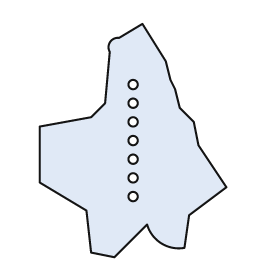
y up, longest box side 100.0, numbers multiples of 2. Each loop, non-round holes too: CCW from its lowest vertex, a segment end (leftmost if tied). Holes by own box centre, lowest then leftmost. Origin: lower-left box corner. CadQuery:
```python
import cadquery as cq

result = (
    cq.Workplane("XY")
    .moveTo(32.0, 0.0)
    .lineTo(46.0, 14.0)
    .threePointArc((52.0, 6.0), (62.0, 4.0))
    .lineTo(64.0, 18.0)
    .lineTo(80.0, 30.0)
    .lineTo(68.0, 48.0)
    .lineTo(66.0, 58.0)
    .lineTo(60.0, 64.0)
    .lineTo(58.0, 72.0)
    .lineTo(56.0, 76.0)
    .lineTo(54.0, 84.0)
    .lineTo(44.0, 100.0)
    .lineTo(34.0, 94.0)
    .threePointArc((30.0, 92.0), (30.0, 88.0))
    .lineTo(28.0, 66.0)
    .lineTo(22.0, 60.0)
    .lineTo(0.0, 56.0)
    .lineTo(0.0, 32.0)
    .lineTo(20.0, 20.0)
    .lineTo(22.0, 2.0)
    .close()
    .moveTo(40.0, 26.0)
    .circle(2.0)
    .moveTo(40.0, 34.0)
    .circle(2.0)
    .moveTo(40.0, 42.0)
    .circle(2.0)
    .moveTo(40.0, 50.0)
    .circle(2.0)
    .moveTo(40.0, 58.0)
    .circle(2.0)
    .moveTo(40.0, 66.0)
    .circle(2.0)
    .moveTo(40.0, 74.0)
    .circle(2.0)
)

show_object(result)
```